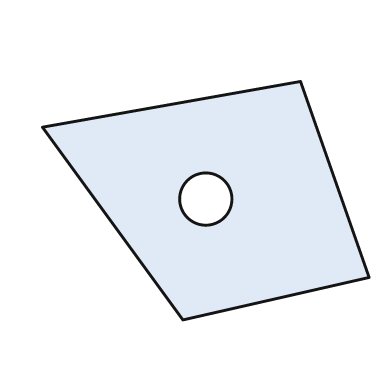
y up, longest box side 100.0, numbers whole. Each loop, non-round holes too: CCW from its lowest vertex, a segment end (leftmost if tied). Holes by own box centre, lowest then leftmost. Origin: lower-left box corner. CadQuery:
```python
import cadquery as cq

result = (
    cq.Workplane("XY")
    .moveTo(43.0, 0.0)
    .lineTo(100.0, 13.0)
    .lineTo(79.0, 73.0)
    .lineTo(0.0, 59.0)
    .close()
    .moveTo(50.0, 37.0)
    .circle(8.0)
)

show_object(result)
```